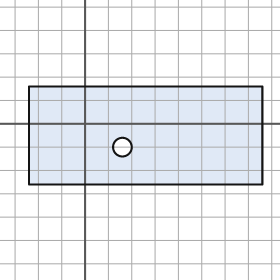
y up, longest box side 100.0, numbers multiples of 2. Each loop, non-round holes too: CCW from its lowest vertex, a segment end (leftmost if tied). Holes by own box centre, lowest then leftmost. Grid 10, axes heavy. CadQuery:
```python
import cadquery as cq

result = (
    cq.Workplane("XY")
    .moveTo(-24.0, -26.0)
    .lineTo(76.0, -26.0)
    .lineTo(76.0, 16.0)
    .lineTo(-24.0, 16.0)
    .close()
    .moveTo(16.0, -10.0)
    .circle(4.0)
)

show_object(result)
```